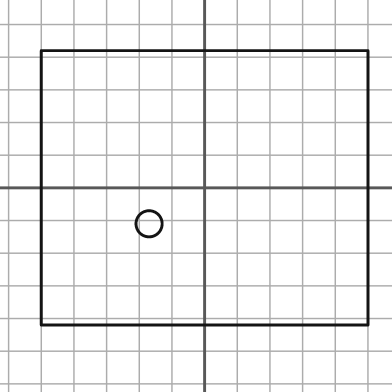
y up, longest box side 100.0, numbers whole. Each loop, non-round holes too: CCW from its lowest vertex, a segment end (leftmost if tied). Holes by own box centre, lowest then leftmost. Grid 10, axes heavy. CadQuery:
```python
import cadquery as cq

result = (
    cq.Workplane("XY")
    .moveTo(-50.0, -42.0)
    .lineTo(50.0, -42.0)
    .lineTo(50.0, 42.0)
    .lineTo(-50.0, 42.0)
    .close()
    .moveTo(-17.0, -11.0)
    .circle(4.0)
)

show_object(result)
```